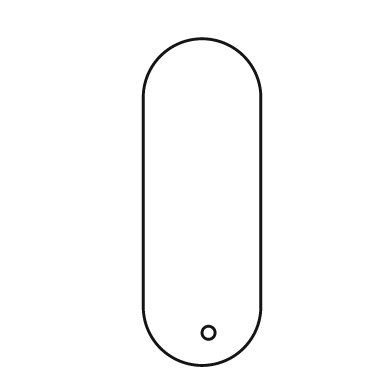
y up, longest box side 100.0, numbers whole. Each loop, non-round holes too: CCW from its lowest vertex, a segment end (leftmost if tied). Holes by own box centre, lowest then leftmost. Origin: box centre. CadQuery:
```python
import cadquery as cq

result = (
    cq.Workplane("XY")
    .moveTo(-18.0, -32.0)
    .threePointArc((0.0, -50.0), (18.0, -32.0))
    .lineTo(18.0, 32.0)
    .threePointArc((0.0, 50.0), (-18.0, 32.0))
    .close()
    .moveTo(2.0, -40.0)
    .circle(2.0)
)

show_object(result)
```